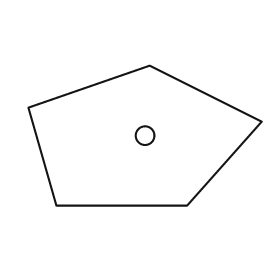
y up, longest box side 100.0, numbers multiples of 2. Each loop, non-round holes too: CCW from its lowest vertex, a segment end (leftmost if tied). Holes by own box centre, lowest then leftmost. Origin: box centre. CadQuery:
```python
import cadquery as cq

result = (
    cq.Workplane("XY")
    .moveTo(-38.0, -30.0)
    .lineTo(18.0, -30.0)
    .lineTo(50.0, 6.0)
    .lineTo(2.0, 30.0)
    .lineTo(-50.0, 12.0)
    .close()
    .moveTo(0.0, 0.0)
    .circle(4.0)
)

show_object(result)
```